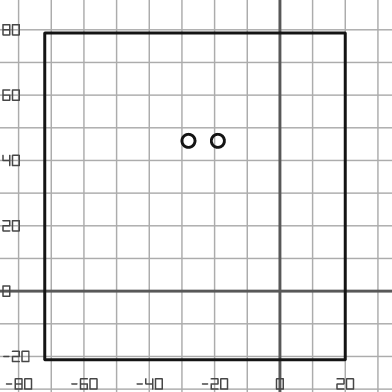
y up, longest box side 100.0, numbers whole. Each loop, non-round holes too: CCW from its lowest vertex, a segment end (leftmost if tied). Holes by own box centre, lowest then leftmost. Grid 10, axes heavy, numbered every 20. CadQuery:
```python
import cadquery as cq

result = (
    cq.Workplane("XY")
    .moveTo(-72.0, -21.0)
    .lineTo(20.0, -21.0)
    .lineTo(20.0, 79.0)
    .lineTo(-72.0, 79.0)
    .close()
    .moveTo(-28.0, 46.0)
    .circle(2.0)
    .moveTo(-19.0, 46.0)
    .circle(2.0)
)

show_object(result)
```